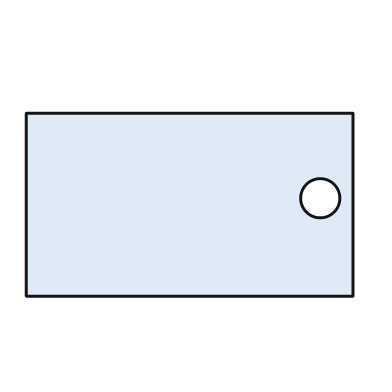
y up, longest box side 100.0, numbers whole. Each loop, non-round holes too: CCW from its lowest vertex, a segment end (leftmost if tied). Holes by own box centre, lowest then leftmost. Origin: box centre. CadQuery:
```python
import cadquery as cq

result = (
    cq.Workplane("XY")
    .moveTo(-50.0, -28.0)
    .lineTo(50.0, -28.0)
    .lineTo(50.0, 28.0)
    .lineTo(-50.0, 28.0)
    .close()
    .moveTo(40.0, 2.0)
    .circle(6.0)
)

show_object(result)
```